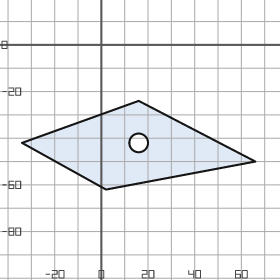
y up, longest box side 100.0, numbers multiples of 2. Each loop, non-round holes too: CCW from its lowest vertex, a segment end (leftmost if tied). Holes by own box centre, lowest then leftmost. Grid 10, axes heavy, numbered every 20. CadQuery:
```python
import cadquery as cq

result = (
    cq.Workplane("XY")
    .moveTo(2.0, -62.0)
    .lineTo(66.0, -50.0)
    .lineTo(16.0, -24.0)
    .lineTo(-34.0, -42.0)
    .close()
    .moveTo(16.0, -42.0)
    .circle(4.0)
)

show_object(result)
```